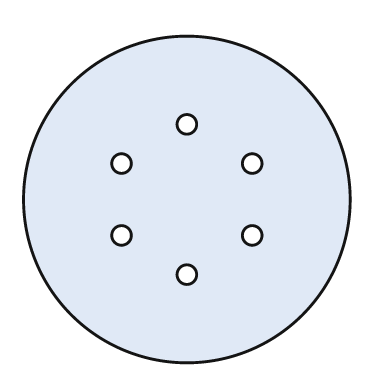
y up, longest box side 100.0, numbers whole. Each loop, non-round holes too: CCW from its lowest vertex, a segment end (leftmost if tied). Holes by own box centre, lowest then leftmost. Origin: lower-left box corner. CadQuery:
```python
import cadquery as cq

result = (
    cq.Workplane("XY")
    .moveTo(50.0, 50.0)
    .circle(50.0)
    .moveTo(50.0, 27.0)
    .circle(3.0)
    .moveTo(30.0, 39.0)
    .circle(3.0)
    .moveTo(70.0, 39.0)
    .circle(3.0)
    .moveTo(30.0, 61.0)
    .circle(3.0)
    .moveTo(70.0, 61.0)
    .circle(3.0)
    .moveTo(50.0, 73.0)
    .circle(3.0)
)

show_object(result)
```